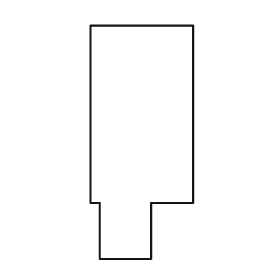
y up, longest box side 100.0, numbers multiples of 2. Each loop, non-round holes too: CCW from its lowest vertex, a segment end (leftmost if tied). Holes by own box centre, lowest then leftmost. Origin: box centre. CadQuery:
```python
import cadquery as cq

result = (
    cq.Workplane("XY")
    .moveTo(-18.0, -50.0)
    .lineTo(4.0, -50.0)
    .lineTo(4.0, -26.0)
    .lineTo(22.0, -26.0)
    .lineTo(22.0, 50.0)
    .lineTo(-22.0, 50.0)
    .lineTo(-22.0, -26.0)
    .lineTo(-18.0, -26.0)
    .close()
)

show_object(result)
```